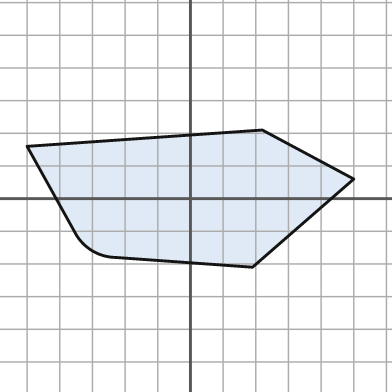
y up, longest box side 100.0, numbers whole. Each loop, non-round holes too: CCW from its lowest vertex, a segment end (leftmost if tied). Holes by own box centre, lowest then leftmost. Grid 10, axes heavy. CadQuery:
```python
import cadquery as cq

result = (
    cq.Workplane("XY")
    .moveTo(19.0, -21.0)
    .lineTo(50.0, 6.0)
    .lineTo(22.0, 21.0)
    .lineTo(-50.0, 16.0)
    .lineTo(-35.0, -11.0)
    .threePointArc((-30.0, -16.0), (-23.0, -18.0))
    .close()
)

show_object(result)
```